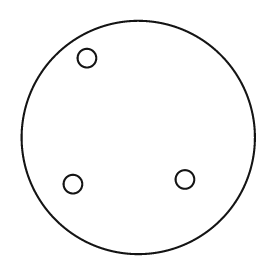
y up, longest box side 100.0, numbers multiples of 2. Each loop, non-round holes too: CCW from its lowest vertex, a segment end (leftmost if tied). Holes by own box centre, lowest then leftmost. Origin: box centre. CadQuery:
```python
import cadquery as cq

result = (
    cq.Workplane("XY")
    .moveTo(0.0, 0.0)
    .circle(50.0)
    .moveTo(-28.0, -20.0)
    .circle(4.0)
    .moveTo(20.0, -18.0)
    .circle(4.0)
    .moveTo(-22.0, 34.0)
    .circle(4.0)
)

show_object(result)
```